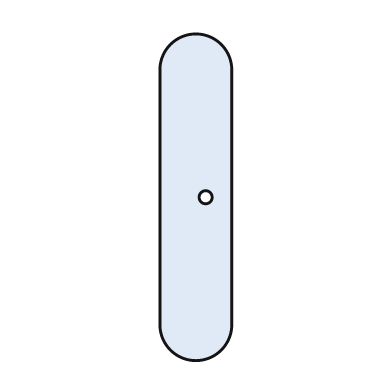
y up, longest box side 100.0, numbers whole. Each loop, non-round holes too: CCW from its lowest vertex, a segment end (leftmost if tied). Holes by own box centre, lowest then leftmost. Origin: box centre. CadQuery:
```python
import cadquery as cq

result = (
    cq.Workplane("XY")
    .moveTo(-11.0, -39.0)
    .threePointArc((0.0, -50.0), (11.0, -39.0))
    .lineTo(11.0, 39.0)
    .threePointArc((0.0, 50.0), (-11.0, 39.0))
    .close()
    .moveTo(3.0, 0.0)
    .circle(2.0)
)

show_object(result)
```